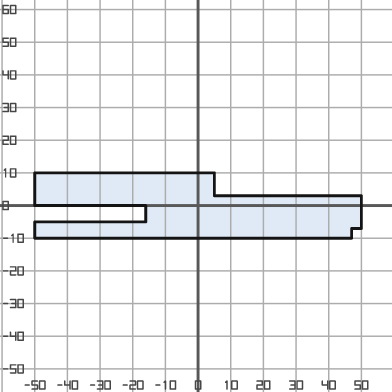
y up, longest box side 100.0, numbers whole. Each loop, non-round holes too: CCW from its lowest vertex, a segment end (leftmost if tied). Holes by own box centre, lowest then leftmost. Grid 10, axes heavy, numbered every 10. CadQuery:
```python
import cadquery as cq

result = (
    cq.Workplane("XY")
    .moveTo(-50.0, -10.0)
    .lineTo(47.0, -10.0)
    .lineTo(47.0, -7.0)
    .lineTo(50.0, -7.0)
    .lineTo(50.0, 3.0)
    .lineTo(5.0, 3.0)
    .lineTo(5.0, 10.0)
    .lineTo(-50.0, 10.0)
    .lineTo(-50.0, 0.0)
    .lineTo(-16.0, 0.0)
    .lineTo(-16.0, -5.0)
    .lineTo(-50.0, -5.0)
    .close()
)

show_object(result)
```